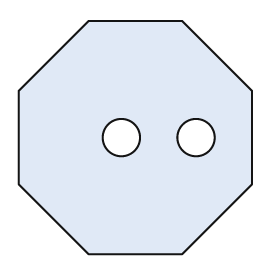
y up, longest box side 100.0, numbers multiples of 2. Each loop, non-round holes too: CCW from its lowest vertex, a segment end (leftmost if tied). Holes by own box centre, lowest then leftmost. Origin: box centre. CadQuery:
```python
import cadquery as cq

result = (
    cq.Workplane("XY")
    .moveTo(-20.0, -50.0)
    .lineTo(20.0, -50.0)
    .lineTo(50.0, -20.0)
    .lineTo(50.0, 20.0)
    .lineTo(20.0, 50.0)
    .lineTo(-20.0, 50.0)
    .lineTo(-50.0, 20.0)
    .lineTo(-50.0, -20.0)
    .close()
    .moveTo(-6.0, 0.0)
    .circle(8.0)
    .moveTo(26.0, 0.0)
    .circle(8.0)
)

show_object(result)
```